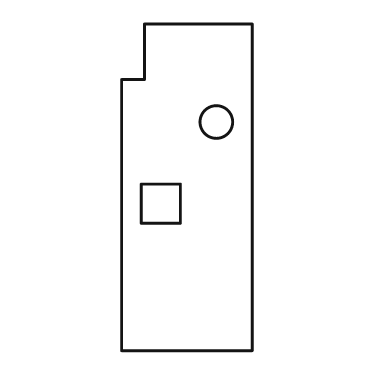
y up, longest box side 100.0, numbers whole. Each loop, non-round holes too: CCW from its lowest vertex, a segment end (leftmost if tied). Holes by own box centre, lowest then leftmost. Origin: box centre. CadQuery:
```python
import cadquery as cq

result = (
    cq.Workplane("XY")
    .moveTo(-20.0, -50.0)
    .lineTo(20.0, -50.0)
    .lineTo(20.0, 50.0)
    .lineTo(-13.0, 50.0)
    .lineTo(-13.0, 33.0)
    .lineTo(-20.0, 33.0)
    .close()
    .moveTo(-14.0, -11.0)
    .lineTo(-2.0, -11.0)
    .lineTo(-2.0, 1.0)
    .lineTo(-14.0, 1.0)
    .close()
    .moveTo(9.0, 20.0)
    .circle(5.0)
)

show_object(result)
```